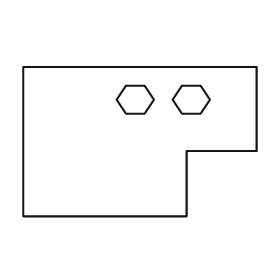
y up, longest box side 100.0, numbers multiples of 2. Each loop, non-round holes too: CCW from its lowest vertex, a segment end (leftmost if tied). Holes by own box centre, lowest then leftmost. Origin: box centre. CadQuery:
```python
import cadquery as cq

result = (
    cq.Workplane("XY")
    .moveTo(-50.0, -32.0)
    .lineTo(20.0, -32.0)
    .lineTo(20.0, -4.0)
    .lineTo(50.0, -4.0)
    .lineTo(50.0, 32.0)
    .lineTo(-50.0, 32.0)
    .close()
    .moveTo(-6.0, 12.0)
    .lineTo(2.0, 12.0)
    .lineTo(6.0, 18.0)
    .lineTo(2.0, 24.0)
    .lineTo(-6.0, 24.0)
    .lineTo(-10.0, 18.0)
    .close()
    .moveTo(18.0, 12.0)
    .lineTo(26.0, 12.0)
    .lineTo(30.0, 18.0)
    .lineTo(26.0, 24.0)
    .lineTo(18.0, 24.0)
    .lineTo(14.0, 18.0)
    .close()
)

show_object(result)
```